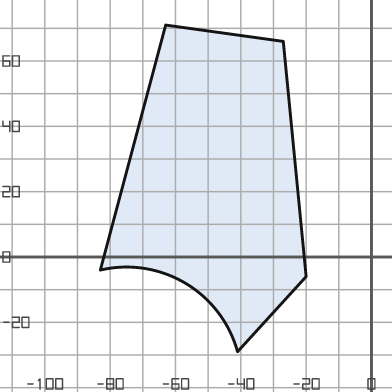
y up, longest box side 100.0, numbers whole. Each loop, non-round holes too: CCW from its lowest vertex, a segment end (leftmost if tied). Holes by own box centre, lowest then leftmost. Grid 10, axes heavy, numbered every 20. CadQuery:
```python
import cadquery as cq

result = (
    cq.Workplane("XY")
    .moveTo(-41.0, -29.0)
    .lineTo(-20.0, -6.0)
    .lineTo(-27.0, 66.0)
    .lineTo(-63.0, 71.0)
    .lineTo(-83.0, -4.0)
    .threePointArc((-57.0, -8.0), (-41.0, -29.0))
    .close()
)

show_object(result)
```